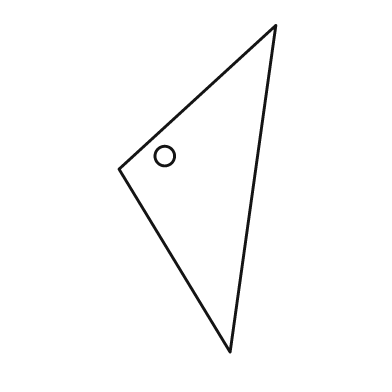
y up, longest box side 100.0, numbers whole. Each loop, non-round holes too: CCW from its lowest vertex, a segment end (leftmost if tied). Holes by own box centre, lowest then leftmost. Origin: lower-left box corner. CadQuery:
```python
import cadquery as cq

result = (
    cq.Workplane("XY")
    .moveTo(34.0, 0.0)
    .lineTo(48.0, 100.0)
    .lineTo(0.0, 56.0)
    .close()
    .moveTo(14.0, 60.0)
    .circle(3.0)
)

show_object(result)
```